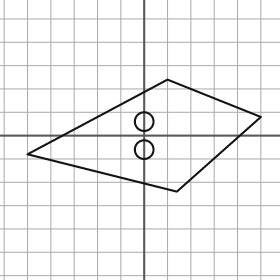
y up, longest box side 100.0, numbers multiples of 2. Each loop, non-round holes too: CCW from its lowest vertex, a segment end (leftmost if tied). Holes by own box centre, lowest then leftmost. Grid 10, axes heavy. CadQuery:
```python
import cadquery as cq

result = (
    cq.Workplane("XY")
    .moveTo(14.0, -24.0)
    .lineTo(50.0, 8.0)
    .lineTo(10.0, 24.0)
    .lineTo(-50.0, -8.0)
    .close()
    .moveTo(0.0, -6.0)
    .circle(4.0)
    .moveTo(0.0, 6.0)
    .circle(4.0)
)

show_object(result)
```